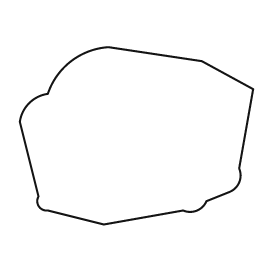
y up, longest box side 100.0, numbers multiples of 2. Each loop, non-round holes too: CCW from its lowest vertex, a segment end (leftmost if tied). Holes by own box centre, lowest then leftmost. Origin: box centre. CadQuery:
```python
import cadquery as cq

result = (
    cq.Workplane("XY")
    .moveTo(-14.0, -38.0)
    .lineTo(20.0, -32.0)
    .threePointArc((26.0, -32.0), (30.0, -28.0))
    .lineTo(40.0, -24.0)
    .threePointArc((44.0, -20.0), (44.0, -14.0))
    .lineTo(50.0, 20.0)
    .lineTo(28.0, 32.0)
    .lineTo(-12.0, 38.0)
    .threePointArc((-28.0, 32.0), (-38.0, 18.0))
    .threePointArc((-46.0, 14.0), (-50.0, 6.0))
    .lineTo(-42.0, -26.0)
    .threePointArc((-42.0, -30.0), (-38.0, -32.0))
    .close()
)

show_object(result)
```